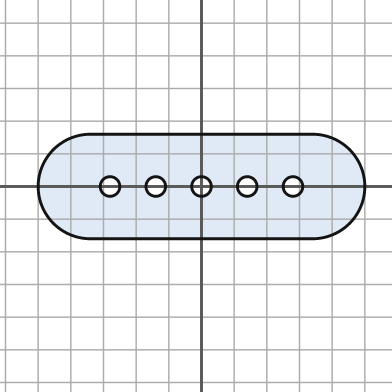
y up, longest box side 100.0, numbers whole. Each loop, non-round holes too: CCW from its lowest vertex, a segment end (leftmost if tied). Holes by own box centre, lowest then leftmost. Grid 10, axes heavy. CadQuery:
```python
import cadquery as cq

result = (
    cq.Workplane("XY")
    .moveTo(-34.0, -16.0)
    .lineTo(34.0, -16.0)
    .threePointArc((50.0, 0.0), (34.0, 16.0))
    .lineTo(-34.0, 16.0)
    .threePointArc((-50.0, 0.0), (-34.0, -16.0))
    .close()
    .moveTo(-28.0, 0.0)
    .circle(3.0)
    .moveTo(-14.0, 0.0)
    .circle(3.0)
    .moveTo(0.0, 0.0)
    .circle(3.0)
    .moveTo(14.0, 0.0)
    .circle(3.0)
    .moveTo(28.0, 0.0)
    .circle(3.0)
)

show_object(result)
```